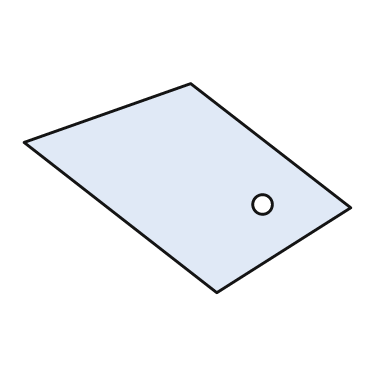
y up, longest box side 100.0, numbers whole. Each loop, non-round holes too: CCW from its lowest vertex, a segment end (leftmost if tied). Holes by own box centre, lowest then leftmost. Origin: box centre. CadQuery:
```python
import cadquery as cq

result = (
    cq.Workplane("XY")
    .moveTo(9.0, -32.0)
    .lineTo(50.0, -6.0)
    .lineTo(1.0, 32.0)
    .lineTo(-50.0, 14.0)
    .close()
    .moveTo(23.0, -5.0)
    .circle(3.0)
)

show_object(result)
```